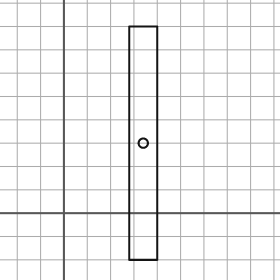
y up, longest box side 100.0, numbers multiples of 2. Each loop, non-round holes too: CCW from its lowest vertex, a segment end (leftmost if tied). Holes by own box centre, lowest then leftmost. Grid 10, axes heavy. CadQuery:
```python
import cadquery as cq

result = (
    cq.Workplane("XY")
    .moveTo(28.0, -20.0)
    .lineTo(40.0, -20.0)
    .lineTo(40.0, 80.0)
    .lineTo(28.0, 80.0)
    .close()
    .moveTo(34.0, 30.0)
    .circle(2.0)
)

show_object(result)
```